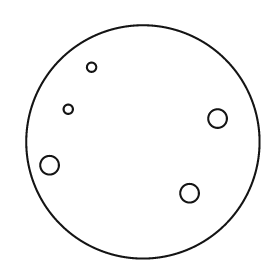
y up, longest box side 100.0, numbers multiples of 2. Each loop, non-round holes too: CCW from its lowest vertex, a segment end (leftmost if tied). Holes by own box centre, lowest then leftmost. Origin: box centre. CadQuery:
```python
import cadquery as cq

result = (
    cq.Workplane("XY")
    .moveTo(0.0, 0.0)
    .circle(50.0)
    .moveTo(20.0, -22.0)
    .circle(4.0)
    .moveTo(-40.0, -10.0)
    .circle(4.0)
    .moveTo(32.0, 10.0)
    .circle(4.0)
    .moveTo(-32.0, 14.0)
    .circle(2.0)
    .moveTo(-22.0, 32.0)
    .circle(2.0)
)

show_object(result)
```